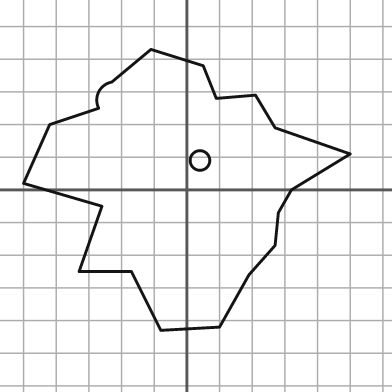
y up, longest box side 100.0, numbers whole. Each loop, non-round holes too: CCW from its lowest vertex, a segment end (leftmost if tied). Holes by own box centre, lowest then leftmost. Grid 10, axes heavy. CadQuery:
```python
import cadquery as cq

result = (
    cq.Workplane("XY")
    .moveTo(-8.0, -43.0)
    .lineTo(10.0, -42.0)
    .lineTo(19.0, -26.0)
    .lineTo(27.0, -17.0)
    .lineTo(28.0, -7.0)
    .lineTo(32.0, 0.0)
    .lineTo(50.0, 11.0)
    .lineTo(27.0, 19.0)
    .lineTo(21.0, 29.0)
    .lineTo(9.0, 28.0)
    .lineTo(5.0, 38.0)
    .lineTo(-11.0, 43.0)
    .lineTo(-23.0, 33.0)
    .threePointArc((-27.0, 30.0), (-27.0, 25.0))
    .lineTo(-42.0, 20.0)
    .lineTo(-50.0, 2.0)
    .lineTo(-26.0, -5.0)
    .lineTo(-33.0, -25.0)
    .lineTo(-17.0, -25.0)
    .close()
    .moveTo(4.0, 9.0)
    .circle(3.0)
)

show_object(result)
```